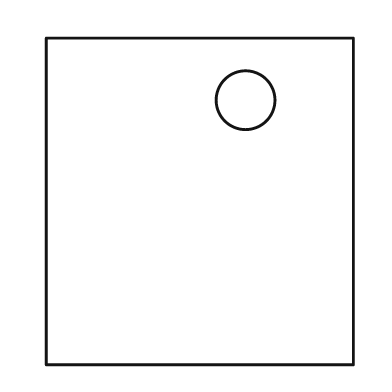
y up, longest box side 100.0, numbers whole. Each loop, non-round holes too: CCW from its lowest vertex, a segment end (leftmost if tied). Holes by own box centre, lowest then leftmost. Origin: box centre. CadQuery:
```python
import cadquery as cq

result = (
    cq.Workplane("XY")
    .moveTo(-47.0, -50.0)
    .lineTo(47.0, -50.0)
    .lineTo(47.0, 50.0)
    .lineTo(-47.0, 50.0)
    .close()
    .moveTo(14.0, 31.0)
    .circle(9.0)
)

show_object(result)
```